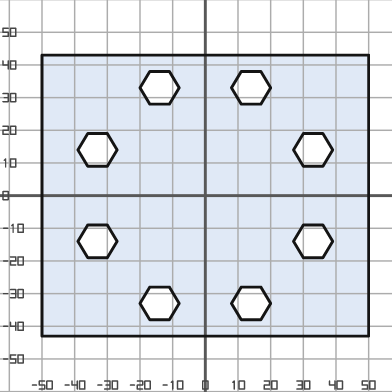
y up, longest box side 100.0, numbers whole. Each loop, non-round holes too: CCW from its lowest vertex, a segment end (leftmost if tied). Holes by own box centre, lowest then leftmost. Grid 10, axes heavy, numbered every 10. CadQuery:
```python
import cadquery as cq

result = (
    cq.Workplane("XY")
    .moveTo(-50.0, -43.0)
    .lineTo(50.0, -43.0)
    .lineTo(50.0, 43.0)
    .lineTo(-50.0, 43.0)
    .close()
    .moveTo(-17.0, -38.0)
    .lineTo(-11.0, -38.0)
    .lineTo(-8.0, -33.0)
    .lineTo(-11.0, -28.0)
    .lineTo(-17.0, -28.0)
    .lineTo(-20.0, -33.0)
    .close()
    .moveTo(11.0, -38.0)
    .lineTo(17.0, -38.0)
    .lineTo(20.0, -33.0)
    .lineTo(17.0, -28.0)
    .lineTo(11.0, -28.0)
    .lineTo(8.0, -33.0)
    .close()
    .moveTo(-36.0, -19.0)
    .lineTo(-30.0, -19.0)
    .lineTo(-27.0, -14.0)
    .lineTo(-30.0, -9.0)
    .lineTo(-36.0, -9.0)
    .lineTo(-39.0, -14.0)
    .close()
    .moveTo(30.0, -19.0)
    .lineTo(36.0, -19.0)
    .lineTo(39.0, -14.0)
    .lineTo(36.0, -9.0)
    .lineTo(30.0, -9.0)
    .lineTo(27.0, -14.0)
    .close()
    .moveTo(-36.0, 9.0)
    .lineTo(-30.0, 9.0)
    .lineTo(-27.0, 14.0)
    .lineTo(-30.0, 19.0)
    .lineTo(-36.0, 19.0)
    .lineTo(-39.0, 14.0)
    .close()
    .moveTo(30.0, 9.0)
    .lineTo(36.0, 9.0)
    .lineTo(39.0, 14.0)
    .lineTo(36.0, 19.0)
    .lineTo(30.0, 19.0)
    .lineTo(27.0, 14.0)
    .close()
    .moveTo(-17.0, 28.0)
    .lineTo(-11.0, 28.0)
    .lineTo(-8.0, 33.0)
    .lineTo(-11.0, 38.0)
    .lineTo(-17.0, 38.0)
    .lineTo(-20.0, 33.0)
    .close()
    .moveTo(11.0, 28.0)
    .lineTo(17.0, 28.0)
    .lineTo(20.0, 33.0)
    .lineTo(17.0, 38.0)
    .lineTo(11.0, 38.0)
    .lineTo(8.0, 33.0)
    .close()
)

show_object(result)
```